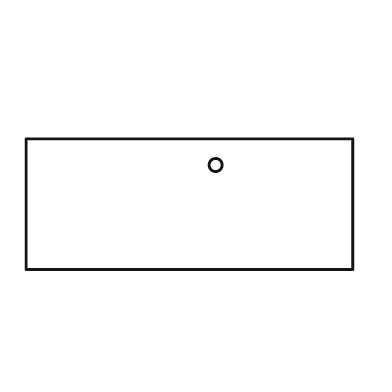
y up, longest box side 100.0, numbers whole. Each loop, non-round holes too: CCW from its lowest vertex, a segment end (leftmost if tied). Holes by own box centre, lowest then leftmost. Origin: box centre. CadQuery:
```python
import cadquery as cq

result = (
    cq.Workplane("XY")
    .moveTo(-50.0, -20.0)
    .lineTo(50.0, -20.0)
    .lineTo(50.0, 20.0)
    .lineTo(-50.0, 20.0)
    .close()
    .moveTo(8.0, 12.0)
    .circle(2.0)
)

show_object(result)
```